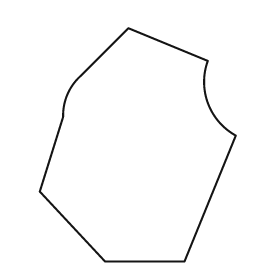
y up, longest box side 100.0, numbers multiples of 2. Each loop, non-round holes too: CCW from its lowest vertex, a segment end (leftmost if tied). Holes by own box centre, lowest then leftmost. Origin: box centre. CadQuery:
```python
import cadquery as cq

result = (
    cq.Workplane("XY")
    .moveTo(-14.0, -50.0)
    .lineTo(20.0, -50.0)
    .lineTo(42.0, 4.0)
    .threePointArc((30.0, 18.0), (30.0, 36.0))
    .lineTo(-4.0, 50.0)
    .lineTo(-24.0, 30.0)
    .threePointArc((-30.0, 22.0), (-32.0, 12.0))
    .lineTo(-42.0, -20.0)
    .close()
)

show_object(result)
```